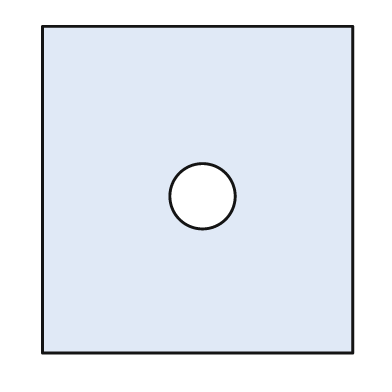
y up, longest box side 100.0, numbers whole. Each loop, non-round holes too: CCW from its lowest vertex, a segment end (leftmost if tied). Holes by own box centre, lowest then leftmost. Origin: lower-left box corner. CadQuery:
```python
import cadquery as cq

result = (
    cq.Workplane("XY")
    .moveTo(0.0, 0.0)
    .lineTo(95.0, 0.0)
    .lineTo(95.0, 100.0)
    .lineTo(0.0, 100.0)
    .close()
    .moveTo(49.0, 48.0)
    .circle(10.0)
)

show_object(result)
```